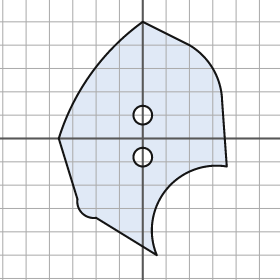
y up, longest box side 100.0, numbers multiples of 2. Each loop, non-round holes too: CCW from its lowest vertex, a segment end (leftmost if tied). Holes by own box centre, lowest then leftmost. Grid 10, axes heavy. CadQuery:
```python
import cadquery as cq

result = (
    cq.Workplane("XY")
    .moveTo(6.0, -50.0)
    .threePointArc((10.0, -22.0), (36.0, -12.0))
    .lineTo(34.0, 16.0)
    .threePointArc((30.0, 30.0), (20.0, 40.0))
    .lineTo(0.0, 50.0)
    .threePointArc((-22.0, 28.0), (-36.0, 0.0))
    .lineTo(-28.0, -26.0)
    .threePointArc((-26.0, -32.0), (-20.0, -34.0))
    .close()
    .moveTo(0.0, -8.0)
    .circle(4.0)
    .moveTo(0.0, 10.0)
    .circle(4.0)
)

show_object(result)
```